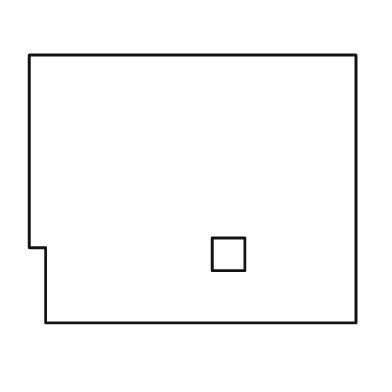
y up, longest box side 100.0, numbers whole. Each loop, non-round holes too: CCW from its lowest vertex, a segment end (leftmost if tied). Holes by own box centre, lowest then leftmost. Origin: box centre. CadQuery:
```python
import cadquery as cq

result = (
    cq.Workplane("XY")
    .moveTo(-45.0, -41.0)
    .lineTo(50.0, -41.0)
    .lineTo(50.0, 41.0)
    .lineTo(-50.0, 41.0)
    .lineTo(-50.0, -18.0)
    .lineTo(-45.0, -18.0)
    .close()
    .moveTo(6.0, -25.0)
    .lineTo(16.0, -25.0)
    .lineTo(16.0, -15.0)
    .lineTo(6.0, -15.0)
    .close()
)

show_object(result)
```